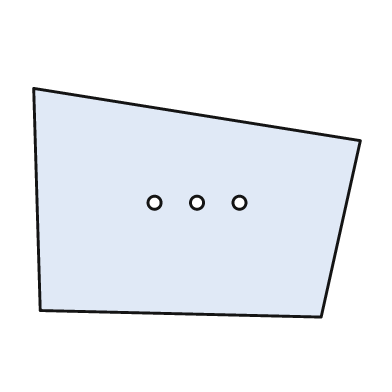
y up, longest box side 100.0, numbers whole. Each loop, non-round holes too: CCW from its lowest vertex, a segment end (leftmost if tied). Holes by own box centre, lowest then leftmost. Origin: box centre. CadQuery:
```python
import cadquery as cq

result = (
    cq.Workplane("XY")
    .moveTo(38.0, -35.0)
    .lineTo(50.0, 19.0)
    .lineTo(-50.0, 35.0)
    .lineTo(-48.0, -33.0)
    .close()
    .moveTo(-13.0, 0.0)
    .circle(2.0)
    .moveTo(0.0, 0.0)
    .circle(2.0)
    .moveTo(13.0, 0.0)
    .circle(2.0)
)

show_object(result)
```